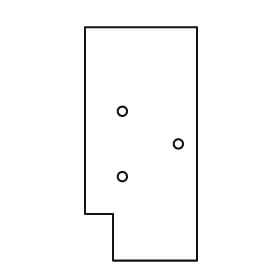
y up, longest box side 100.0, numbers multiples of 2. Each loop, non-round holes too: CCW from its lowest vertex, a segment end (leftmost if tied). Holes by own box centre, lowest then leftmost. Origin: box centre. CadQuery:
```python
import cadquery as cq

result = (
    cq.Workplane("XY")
    .moveTo(-12.0, -50.0)
    .lineTo(24.0, -50.0)
    .lineTo(24.0, 50.0)
    .lineTo(-24.0, 50.0)
    .lineTo(-24.0, -30.0)
    .lineTo(-12.0, -30.0)
    .close()
    .moveTo(-8.0, -14.0)
    .circle(2.0)
    .moveTo(16.0, 0.0)
    .circle(2.0)
    .moveTo(-8.0, 14.0)
    .circle(2.0)
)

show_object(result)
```